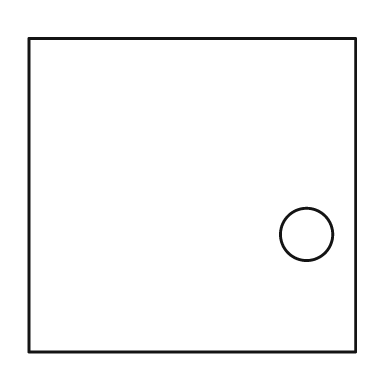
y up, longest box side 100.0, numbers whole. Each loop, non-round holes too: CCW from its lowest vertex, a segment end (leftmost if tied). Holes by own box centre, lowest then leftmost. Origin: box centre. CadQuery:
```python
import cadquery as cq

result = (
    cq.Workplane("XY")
    .moveTo(-50.0, -48.0)
    .lineTo(50.0, -48.0)
    .lineTo(50.0, 48.0)
    .lineTo(-50.0, 48.0)
    .close()
    .moveTo(35.0, -12.0)
    .circle(8.0)
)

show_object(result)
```